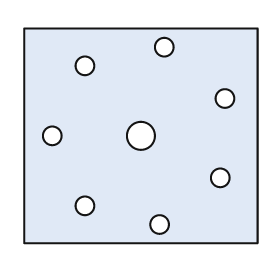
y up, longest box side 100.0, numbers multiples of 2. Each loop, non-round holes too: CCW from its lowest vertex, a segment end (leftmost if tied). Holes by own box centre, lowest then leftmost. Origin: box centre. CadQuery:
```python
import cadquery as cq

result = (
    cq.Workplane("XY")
    .moveTo(-50.0, -46.0)
    .lineTo(50.0, -46.0)
    .lineTo(50.0, 46.0)
    .lineTo(-50.0, 46.0)
    .close()
    .moveTo(8.0, -38.0)
    .circle(4.0)
    .moveTo(-24.0, -30.0)
    .circle(4.0)
    .moveTo(34.0, -18.0)
    .circle(4.0)
    .moveTo(-38.0, 0.0)
    .circle(4.0)
    .moveTo(0.0, 0.0)
    .circle(6.0)
    .moveTo(36.0, 16.0)
    .circle(4.0)
    .moveTo(-24.0, 30.0)
    .circle(4.0)
    .moveTo(10.0, 38.0)
    .circle(4.0)
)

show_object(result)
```